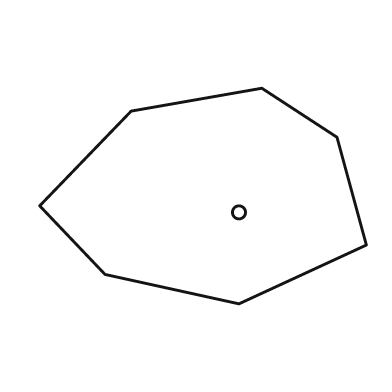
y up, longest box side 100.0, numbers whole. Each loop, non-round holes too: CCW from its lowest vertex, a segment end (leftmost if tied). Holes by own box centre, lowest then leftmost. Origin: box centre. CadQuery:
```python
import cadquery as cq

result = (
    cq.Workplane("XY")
    .moveTo(11.0, -33.0)
    .lineTo(50.0, -15.0)
    .lineTo(41.0, 18.0)
    .lineTo(18.0, 33.0)
    .lineTo(-22.0, 26.0)
    .lineTo(-50.0, -3.0)
    .lineTo(-30.0, -24.0)
    .close()
    .moveTo(11.0, -5.0)
    .circle(2.0)
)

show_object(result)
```